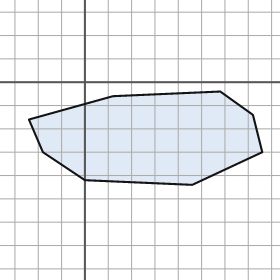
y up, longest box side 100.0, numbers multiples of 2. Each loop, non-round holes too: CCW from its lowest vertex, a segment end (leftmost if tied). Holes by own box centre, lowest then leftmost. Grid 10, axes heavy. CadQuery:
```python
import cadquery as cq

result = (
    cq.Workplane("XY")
    .moveTo(46.0, -44.0)
    .lineTo(76.0, -30.0)
    .lineTo(72.0, -14.0)
    .lineTo(58.0, -4.0)
    .lineTo(12.0, -6.0)
    .lineTo(-24.0, -16.0)
    .lineTo(-18.0, -30.0)
    .lineTo(0.0, -42.0)
    .close()
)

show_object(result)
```